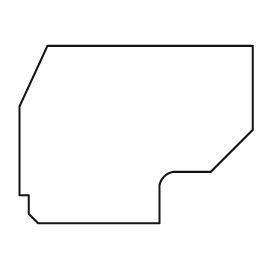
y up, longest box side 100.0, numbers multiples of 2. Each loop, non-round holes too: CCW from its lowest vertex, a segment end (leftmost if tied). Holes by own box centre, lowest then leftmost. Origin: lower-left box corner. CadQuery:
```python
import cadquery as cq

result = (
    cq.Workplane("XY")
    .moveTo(8.0, 0.0)
    .lineTo(60.0, 0.0)
    .lineTo(60.0, 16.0)
    .threePointArc((62.0, 20.0), (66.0, 22.0))
    .lineTo(82.0, 22.0)
    .lineTo(100.0, 40.0)
    .lineTo(100.0, 76.0)
    .lineTo(12.0, 76.0)
    .lineTo(0.0, 50.0)
    .lineTo(0.0, 12.0)
    .lineTo(4.0, 12.0)
    .lineTo(4.0, 4.0)
    .close()
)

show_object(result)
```